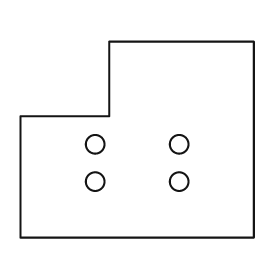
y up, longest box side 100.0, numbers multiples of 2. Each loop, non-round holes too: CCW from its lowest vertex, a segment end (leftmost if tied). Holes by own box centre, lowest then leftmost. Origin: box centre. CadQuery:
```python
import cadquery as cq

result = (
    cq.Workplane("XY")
    .moveTo(-50.0, -42.0)
    .lineTo(50.0, -42.0)
    .lineTo(50.0, 42.0)
    .lineTo(-12.0, 42.0)
    .lineTo(-12.0, 10.0)
    .lineTo(-50.0, 10.0)
    .close()
    .moveTo(-18.0, -18.0)
    .circle(4.0)
    .moveTo(18.0, -18.0)
    .circle(4.0)
    .moveTo(-18.0, -2.0)
    .circle(4.0)
    .moveTo(18.0, -2.0)
    .circle(4.0)
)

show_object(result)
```